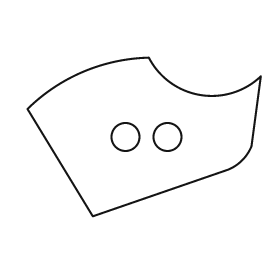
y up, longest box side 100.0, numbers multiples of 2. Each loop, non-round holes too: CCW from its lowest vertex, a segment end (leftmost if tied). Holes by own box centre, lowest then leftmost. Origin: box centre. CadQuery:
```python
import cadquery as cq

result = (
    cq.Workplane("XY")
    .moveTo(-22.0, -34.0)
    .lineTo(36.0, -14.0)
    .threePointArc((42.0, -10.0), (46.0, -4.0))
    .lineTo(50.0, 26.0)
    .threePointArc((24.0, 18.0), (2.0, 34.0))
    .threePointArc((-26.0, 28.0), (-50.0, 12.0))
    .close()
    .moveTo(-8.0, 0.0)
    .circle(6.0)
    .moveTo(10.0, 0.0)
    .circle(6.0)
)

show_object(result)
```